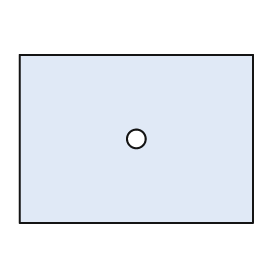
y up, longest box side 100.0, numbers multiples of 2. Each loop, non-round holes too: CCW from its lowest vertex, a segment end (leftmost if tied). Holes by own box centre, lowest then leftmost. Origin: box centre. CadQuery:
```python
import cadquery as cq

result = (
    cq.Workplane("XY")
    .moveTo(-50.0, -36.0)
    .lineTo(50.0, -36.0)
    .lineTo(50.0, 36.0)
    .lineTo(-50.0, 36.0)
    .close()
    .moveTo(0.0, 0.0)
    .circle(4.0)
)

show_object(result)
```